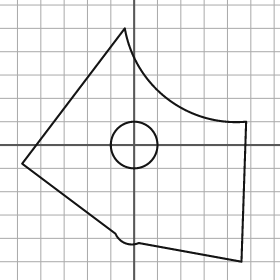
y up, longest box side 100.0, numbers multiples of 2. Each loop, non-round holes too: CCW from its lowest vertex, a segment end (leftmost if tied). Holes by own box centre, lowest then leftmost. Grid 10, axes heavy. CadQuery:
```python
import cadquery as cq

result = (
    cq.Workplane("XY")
    .moveTo(46.0, -50.0)
    .lineTo(48.0, 10.0)
    .threePointArc((14.0, 20.0), (-4.0, 50.0))
    .lineTo(-48.0, -8.0)
    .lineTo(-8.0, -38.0)
    .threePointArc((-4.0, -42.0), (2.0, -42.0))
    .close()
    .moveTo(0.0, 0.0)
    .circle(10.0)
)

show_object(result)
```